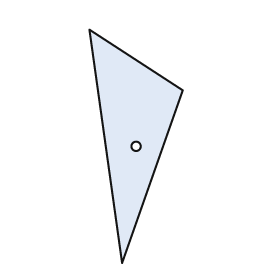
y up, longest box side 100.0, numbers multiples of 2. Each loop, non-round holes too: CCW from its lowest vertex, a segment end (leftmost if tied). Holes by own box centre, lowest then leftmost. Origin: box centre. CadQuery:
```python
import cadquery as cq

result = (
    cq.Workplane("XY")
    .moveTo(-6.0, -50.0)
    .lineTo(20.0, 24.0)
    .lineTo(-20.0, 50.0)
    .close()
    .moveTo(0.0, 0.0)
    .circle(2.0)
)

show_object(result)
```